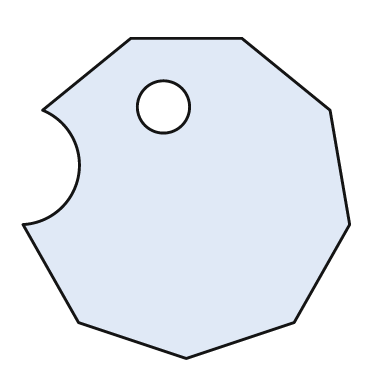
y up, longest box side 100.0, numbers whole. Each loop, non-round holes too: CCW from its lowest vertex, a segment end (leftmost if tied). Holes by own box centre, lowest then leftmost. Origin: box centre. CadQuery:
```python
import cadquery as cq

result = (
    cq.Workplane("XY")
    .moveTo(0.0, -49.0)
    .lineTo(33.0, -38.0)
    .lineTo(50.0, -8.0)
    .lineTo(44.0, 27.0)
    .lineTo(17.0, 49.0)
    .lineTo(-17.0, 49.0)
    .lineTo(-44.0, 27.0)
    .threePointArc((-33.0, 7.0), (-50.0, -8.0))
    .lineTo(-33.0, -38.0)
    .close()
    .moveTo(-7.0, 28.0)
    .circle(8.0)
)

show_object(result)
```